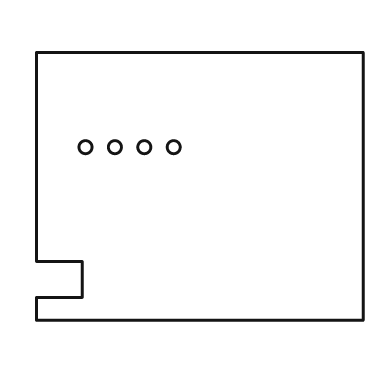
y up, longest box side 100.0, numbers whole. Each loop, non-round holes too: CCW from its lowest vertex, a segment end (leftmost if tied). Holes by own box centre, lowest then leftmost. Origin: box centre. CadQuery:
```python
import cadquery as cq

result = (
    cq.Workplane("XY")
    .moveTo(-50.0, -41.0)
    .lineTo(50.0, -41.0)
    .lineTo(50.0, 41.0)
    .lineTo(-50.0, 41.0)
    .lineTo(-50.0, -23.0)
    .lineTo(-36.0, -23.0)
    .lineTo(-36.0, -34.0)
    .lineTo(-50.0, -34.0)
    .close()
    .moveTo(-35.0, 12.0)
    .circle(2.0)
    .moveTo(-26.0, 12.0)
    .circle(2.0)
    .moveTo(-17.0, 12.0)
    .circle(2.0)
    .moveTo(-8.0, 12.0)
    .circle(2.0)
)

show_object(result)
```